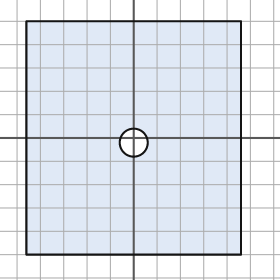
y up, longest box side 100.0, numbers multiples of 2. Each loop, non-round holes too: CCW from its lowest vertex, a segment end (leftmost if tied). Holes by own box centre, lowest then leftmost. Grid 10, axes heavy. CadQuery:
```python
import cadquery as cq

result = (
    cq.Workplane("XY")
    .moveTo(-46.0, -50.0)
    .lineTo(46.0, -50.0)
    .lineTo(46.0, 50.0)
    .lineTo(-46.0, 50.0)
    .close()
    .moveTo(0.0, -2.0)
    .circle(6.0)
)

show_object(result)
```